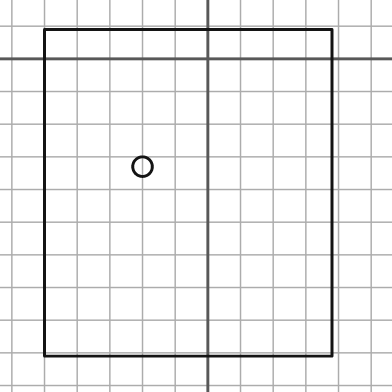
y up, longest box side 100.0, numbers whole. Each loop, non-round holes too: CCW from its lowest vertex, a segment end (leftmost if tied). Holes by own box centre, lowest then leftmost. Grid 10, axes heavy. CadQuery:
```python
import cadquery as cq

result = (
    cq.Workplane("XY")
    .moveTo(-50.0, -91.0)
    .lineTo(38.0, -91.0)
    .lineTo(38.0, 9.0)
    .lineTo(-50.0, 9.0)
    .close()
    .moveTo(-20.0, -33.0)
    .circle(3.0)
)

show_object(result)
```